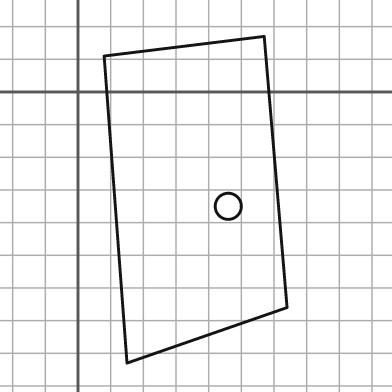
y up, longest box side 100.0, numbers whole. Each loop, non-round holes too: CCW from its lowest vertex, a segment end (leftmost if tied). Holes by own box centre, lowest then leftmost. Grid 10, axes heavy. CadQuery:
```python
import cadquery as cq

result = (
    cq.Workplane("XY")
    .moveTo(15.0, -83.0)
    .lineTo(64.0, -66.0)
    .lineTo(57.0, 17.0)
    .lineTo(8.0, 11.0)
    .close()
    .moveTo(46.0, -35.0)
    .circle(4.0)
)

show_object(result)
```